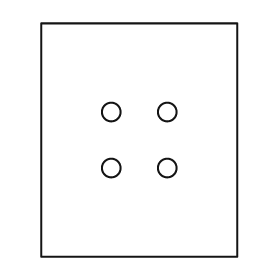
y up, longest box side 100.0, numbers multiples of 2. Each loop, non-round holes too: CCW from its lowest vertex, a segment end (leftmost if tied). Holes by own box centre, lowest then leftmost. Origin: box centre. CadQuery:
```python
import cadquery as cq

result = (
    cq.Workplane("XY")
    .moveTo(-42.0, -50.0)
    .lineTo(42.0, -50.0)
    .lineTo(42.0, 50.0)
    .lineTo(-42.0, 50.0)
    .close()
    .moveTo(-12.0, -12.0)
    .circle(4.0)
    .moveTo(12.0, -12.0)
    .circle(4.0)
    .moveTo(-12.0, 12.0)
    .circle(4.0)
    .moveTo(12.0, 12.0)
    .circle(4.0)
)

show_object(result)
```